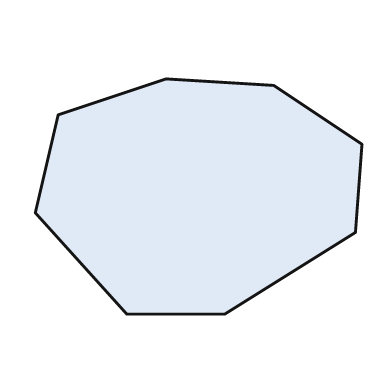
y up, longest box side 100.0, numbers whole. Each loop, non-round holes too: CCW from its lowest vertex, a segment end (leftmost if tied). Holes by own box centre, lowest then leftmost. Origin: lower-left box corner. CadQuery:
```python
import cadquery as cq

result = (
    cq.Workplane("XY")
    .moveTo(28.0, 0.0)
    .lineTo(58.0, 0.0)
    .lineTo(98.0, 25.0)
    .lineTo(100.0, 52.0)
    .lineTo(73.0, 70.0)
    .lineTo(40.0, 72.0)
    .lineTo(7.0, 61.0)
    .lineTo(0.0, 31.0)
    .close()
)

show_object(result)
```